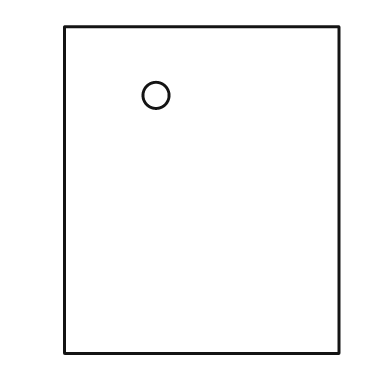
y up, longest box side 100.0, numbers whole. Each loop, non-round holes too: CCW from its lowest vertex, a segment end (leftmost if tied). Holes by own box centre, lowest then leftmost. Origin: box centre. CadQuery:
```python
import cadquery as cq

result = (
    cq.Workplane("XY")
    .moveTo(-42.0, -50.0)
    .lineTo(42.0, -50.0)
    .lineTo(42.0, 50.0)
    .lineTo(-42.0, 50.0)
    .close()
    .moveTo(-14.0, 29.0)
    .circle(4.0)
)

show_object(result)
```